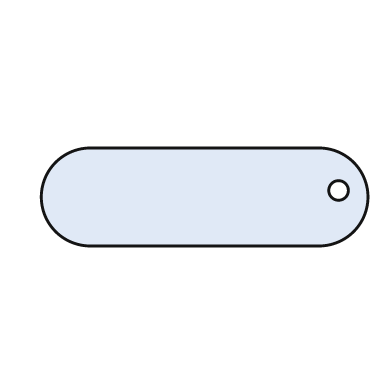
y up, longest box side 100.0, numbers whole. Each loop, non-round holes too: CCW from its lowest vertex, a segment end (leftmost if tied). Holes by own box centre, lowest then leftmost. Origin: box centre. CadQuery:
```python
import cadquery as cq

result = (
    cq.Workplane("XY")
    .moveTo(-35.0, -15.0)
    .lineTo(35.0, -15.0)
    .threePointArc((50.0, 0.0), (35.0, 15.0))
    .lineTo(-35.0, 15.0)
    .threePointArc((-50.0, 0.0), (-35.0, -15.0))
    .close()
    .moveTo(41.0, 2.0)
    .circle(3.0)
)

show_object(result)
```